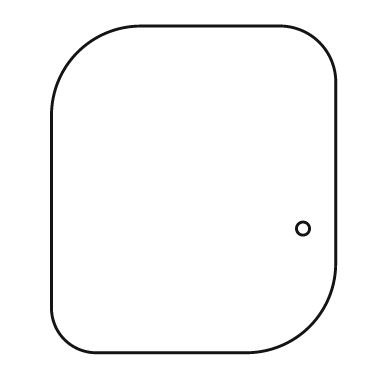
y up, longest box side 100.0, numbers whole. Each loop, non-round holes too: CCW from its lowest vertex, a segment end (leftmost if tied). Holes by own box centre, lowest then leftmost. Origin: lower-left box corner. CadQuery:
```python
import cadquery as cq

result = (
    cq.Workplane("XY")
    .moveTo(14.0, 0.0)
    .lineTo(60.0, 0.0)
    .threePointArc((79.0, 8.0), (87.0, 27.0))
    .lineTo(87.0, 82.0)
    .threePointArc((82.0, 95.0), (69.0, 100.0))
    .lineTo(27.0, 100.0)
    .threePointArc((8.0, 92.0), (0.0, 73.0))
    .lineTo(0.0, 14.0)
    .threePointArc((4.0, 4.0), (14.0, 0.0))
    .close()
    .moveTo(77.0, 38.0)
    .circle(2.0)
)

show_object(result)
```